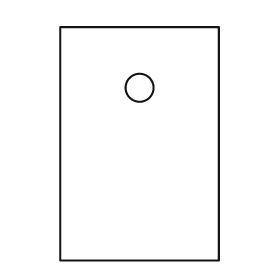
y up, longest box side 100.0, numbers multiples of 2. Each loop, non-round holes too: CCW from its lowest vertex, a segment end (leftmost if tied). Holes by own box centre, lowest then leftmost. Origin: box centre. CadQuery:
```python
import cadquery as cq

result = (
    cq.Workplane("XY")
    .moveTo(-34.0, -50.0)
    .lineTo(34.0, -50.0)
    .lineTo(34.0, 50.0)
    .lineTo(-34.0, 50.0)
    .close()
    .moveTo(0.0, 24.0)
    .circle(6.0)
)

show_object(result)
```